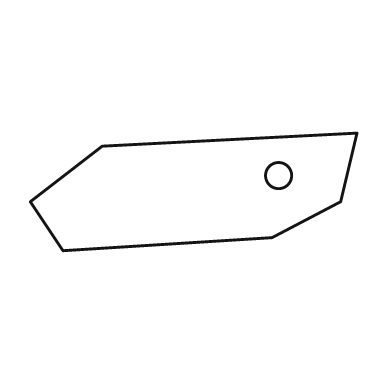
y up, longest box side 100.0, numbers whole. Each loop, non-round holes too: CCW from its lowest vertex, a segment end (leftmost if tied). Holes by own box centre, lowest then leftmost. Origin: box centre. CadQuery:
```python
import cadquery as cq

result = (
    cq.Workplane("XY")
    .moveTo(-40.0, -18.0)
    .lineTo(24.0, -14.0)
    .lineTo(45.0, -3.0)
    .lineTo(50.0, 18.0)
    .lineTo(-28.0, 14.0)
    .lineTo(-50.0, -3.0)
    .close()
    .moveTo(26.0, 5.0)
    .circle(4.0)
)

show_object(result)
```